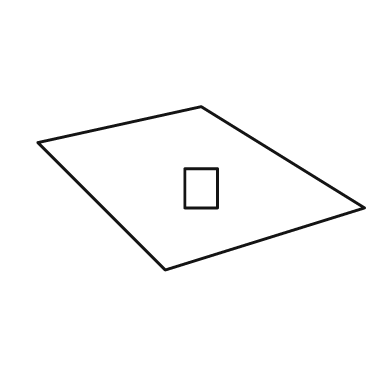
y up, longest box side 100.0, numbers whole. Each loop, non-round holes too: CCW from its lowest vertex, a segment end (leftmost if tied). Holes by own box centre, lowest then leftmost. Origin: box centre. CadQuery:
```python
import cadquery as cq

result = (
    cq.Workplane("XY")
    .moveTo(-11.0, -25.0)
    .lineTo(50.0, -6.0)
    .lineTo(0.0, 25.0)
    .lineTo(-50.0, 14.0)
    .close()
    .moveTo(-5.0, -6.0)
    .lineTo(5.0, -6.0)
    .lineTo(5.0, 6.0)
    .lineTo(-5.0, 6.0)
    .close()
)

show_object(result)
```